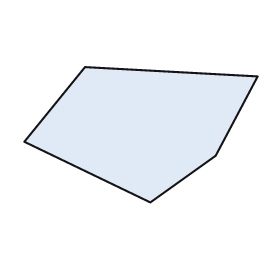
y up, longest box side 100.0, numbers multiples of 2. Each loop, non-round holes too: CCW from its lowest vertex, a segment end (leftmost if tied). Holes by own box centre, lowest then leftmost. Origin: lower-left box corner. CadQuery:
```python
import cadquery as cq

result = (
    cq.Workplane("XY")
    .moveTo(54.0, 0.0)
    .lineTo(82.0, 20.0)
    .lineTo(100.0, 54.0)
    .lineTo(26.0, 58.0)
    .lineTo(0.0, 26.0)
    .close()
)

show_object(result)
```